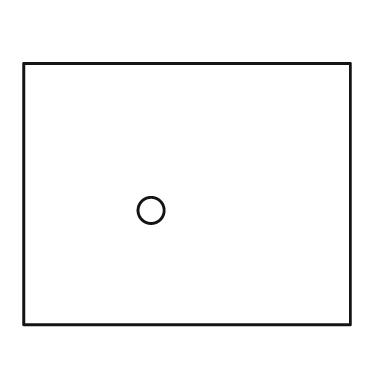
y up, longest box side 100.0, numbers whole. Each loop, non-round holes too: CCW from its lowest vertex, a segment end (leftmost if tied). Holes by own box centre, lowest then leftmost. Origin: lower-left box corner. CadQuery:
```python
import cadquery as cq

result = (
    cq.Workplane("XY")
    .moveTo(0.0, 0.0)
    .lineTo(100.0, 0.0)
    .lineTo(100.0, 80.0)
    .lineTo(0.0, 80.0)
    .close()
    .moveTo(39.0, 35.0)
    .circle(4.0)
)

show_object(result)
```